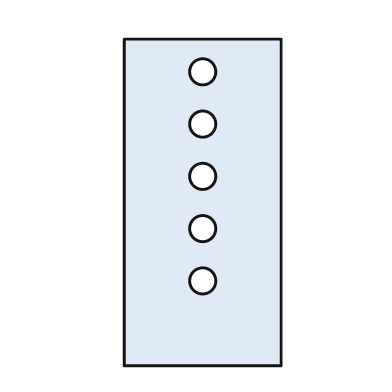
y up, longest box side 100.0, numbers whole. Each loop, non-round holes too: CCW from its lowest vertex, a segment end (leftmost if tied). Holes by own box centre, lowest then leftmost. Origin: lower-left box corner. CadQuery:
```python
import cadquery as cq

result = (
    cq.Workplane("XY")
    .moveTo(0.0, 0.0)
    .lineTo(48.0, 0.0)
    .lineTo(48.0, 100.0)
    .lineTo(0.0, 100.0)
    .close()
    .moveTo(24.0, 26.0)
    .circle(4.0)
    .moveTo(24.0, 42.0)
    .circle(4.0)
    .moveTo(24.0, 58.0)
    .circle(4.0)
    .moveTo(24.0, 74.0)
    .circle(4.0)
    .moveTo(24.0, 90.0)
    .circle(4.0)
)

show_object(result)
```